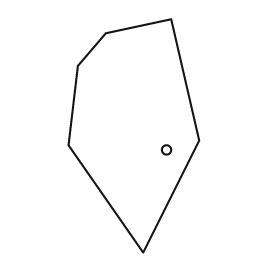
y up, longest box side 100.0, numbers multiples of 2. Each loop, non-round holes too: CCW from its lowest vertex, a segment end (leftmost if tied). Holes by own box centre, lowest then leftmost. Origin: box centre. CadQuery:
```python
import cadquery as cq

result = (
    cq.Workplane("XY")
    .moveTo(4.0, -50.0)
    .lineTo(28.0, -2.0)
    .lineTo(16.0, 50.0)
    .lineTo(-12.0, 44.0)
    .lineTo(-24.0, 30.0)
    .lineTo(-28.0, -4.0)
    .close()
    .moveTo(14.0, -6.0)
    .circle(2.0)
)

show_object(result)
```